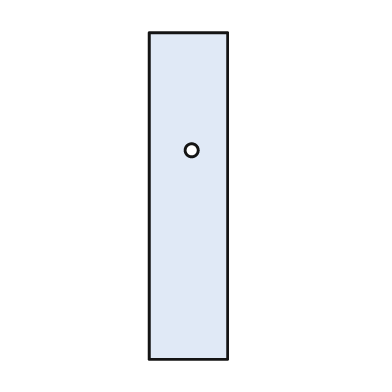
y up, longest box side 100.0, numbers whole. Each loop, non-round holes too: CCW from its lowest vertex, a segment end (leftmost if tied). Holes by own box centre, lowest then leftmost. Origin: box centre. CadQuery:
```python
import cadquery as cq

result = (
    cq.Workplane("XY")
    .moveTo(-12.0, -50.0)
    .lineTo(12.0, -50.0)
    .lineTo(12.0, 50.0)
    .lineTo(-12.0, 50.0)
    .close()
    .moveTo(1.0, 14.0)
    .circle(2.0)
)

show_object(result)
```